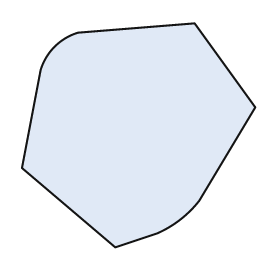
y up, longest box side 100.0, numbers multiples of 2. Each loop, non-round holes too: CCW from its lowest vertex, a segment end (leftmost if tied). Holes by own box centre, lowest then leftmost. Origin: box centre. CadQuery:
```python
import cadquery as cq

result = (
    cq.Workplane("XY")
    .moveTo(-10.0, -48.0)
    .lineTo(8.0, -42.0)
    .threePointArc((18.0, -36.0), (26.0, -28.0))
    .lineTo(50.0, 12.0)
    .lineTo(24.0, 48.0)
    .lineTo(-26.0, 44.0)
    .threePointArc((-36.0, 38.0), (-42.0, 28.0))
    .lineTo(-50.0, -14.0)
    .close()
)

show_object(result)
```